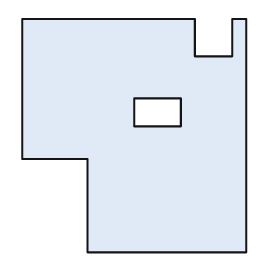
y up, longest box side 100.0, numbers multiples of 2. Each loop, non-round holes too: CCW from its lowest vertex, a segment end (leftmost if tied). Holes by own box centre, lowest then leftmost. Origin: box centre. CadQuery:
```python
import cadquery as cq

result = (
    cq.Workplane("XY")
    .moveTo(-20.0, -50.0)
    .lineTo(48.0, -50.0)
    .lineTo(48.0, 50.0)
    .lineTo(42.0, 50.0)
    .lineTo(42.0, 34.0)
    .lineTo(26.0, 34.0)
    .lineTo(26.0, 50.0)
    .lineTo(-48.0, 50.0)
    .lineTo(-48.0, -10.0)
    .lineTo(-20.0, -10.0)
    .close()
    .moveTo(0.0, 4.0)
    .lineTo(20.0, 4.0)
    .lineTo(20.0, 16.0)
    .lineTo(0.0, 16.0)
    .close()
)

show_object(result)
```